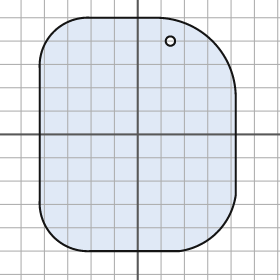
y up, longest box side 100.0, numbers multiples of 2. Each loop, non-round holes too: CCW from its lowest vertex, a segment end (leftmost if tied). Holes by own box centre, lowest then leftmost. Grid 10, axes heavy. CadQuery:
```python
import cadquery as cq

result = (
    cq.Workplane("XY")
    .moveTo(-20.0, -50.0)
    .lineTo(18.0, -50.0)
    .threePointArc((34.0, -42.0), (42.0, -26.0))
    .lineTo(42.0, 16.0)
    .threePointArc((32.0, 40.0), (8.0, 50.0))
    .lineTo(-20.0, 50.0)
    .threePointArc((-36.0, 44.0), (-42.0, 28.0))
    .lineTo(-42.0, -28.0)
    .threePointArc((-36.0, -44.0), (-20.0, -50.0))
    .close()
    .moveTo(14.0, 40.0)
    .circle(2.0)
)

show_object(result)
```